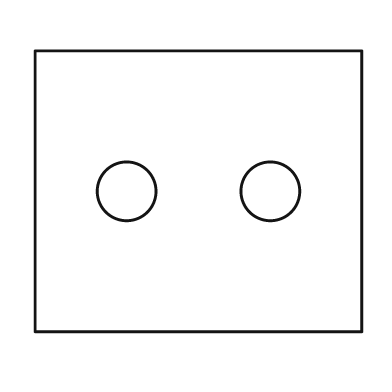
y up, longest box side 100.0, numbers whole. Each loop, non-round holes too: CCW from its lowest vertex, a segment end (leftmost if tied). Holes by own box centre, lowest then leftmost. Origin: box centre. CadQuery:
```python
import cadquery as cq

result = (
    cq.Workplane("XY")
    .moveTo(-50.0, -43.0)
    .lineTo(50.0, -43.0)
    .lineTo(50.0, 43.0)
    .lineTo(-50.0, 43.0)
    .close()
    .moveTo(-22.0, 0.0)
    .circle(9.0)
    .moveTo(22.0, 0.0)
    .circle(9.0)
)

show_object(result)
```